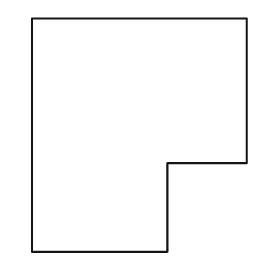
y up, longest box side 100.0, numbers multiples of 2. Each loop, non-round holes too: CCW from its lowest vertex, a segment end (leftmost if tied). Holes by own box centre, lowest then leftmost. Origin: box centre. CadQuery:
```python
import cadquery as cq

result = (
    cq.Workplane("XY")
    .moveTo(-46.0, -50.0)
    .lineTo(12.0, -50.0)
    .lineTo(12.0, -12.0)
    .lineTo(46.0, -12.0)
    .lineTo(46.0, 50.0)
    .lineTo(-46.0, 50.0)
    .close()
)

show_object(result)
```